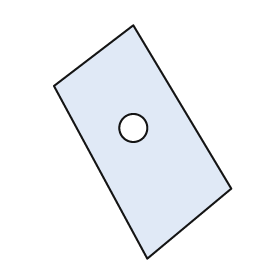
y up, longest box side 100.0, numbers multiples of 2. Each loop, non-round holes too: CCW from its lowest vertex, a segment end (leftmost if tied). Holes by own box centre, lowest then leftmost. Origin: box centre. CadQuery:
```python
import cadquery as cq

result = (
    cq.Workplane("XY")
    .moveTo(2.0, -50.0)
    .lineTo(38.0, -20.0)
    .lineTo(-4.0, 50.0)
    .lineTo(-38.0, 24.0)
    .close()
    .moveTo(-4.0, 6.0)
    .circle(6.0)
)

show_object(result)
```